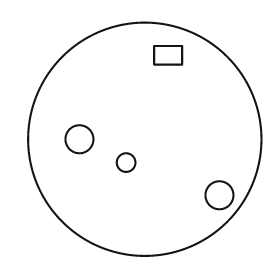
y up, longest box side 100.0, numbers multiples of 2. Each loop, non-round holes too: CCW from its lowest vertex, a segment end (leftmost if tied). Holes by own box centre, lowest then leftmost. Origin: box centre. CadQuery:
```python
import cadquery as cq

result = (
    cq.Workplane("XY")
    .moveTo(0.0, 0.0)
    .circle(50.0)
    .moveTo(32.0, -24.0)
    .circle(6.0)
    .moveTo(-8.0, -10.0)
    .circle(4.0)
    .moveTo(-28.0, 0.0)
    .circle(6.0)
    .moveTo(4.0, 32.0)
    .lineTo(16.0, 32.0)
    .lineTo(16.0, 40.0)
    .lineTo(4.0, 40.0)
    .close()
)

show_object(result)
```